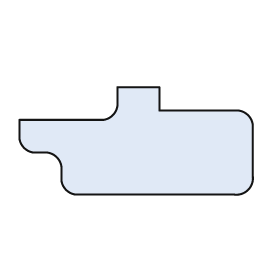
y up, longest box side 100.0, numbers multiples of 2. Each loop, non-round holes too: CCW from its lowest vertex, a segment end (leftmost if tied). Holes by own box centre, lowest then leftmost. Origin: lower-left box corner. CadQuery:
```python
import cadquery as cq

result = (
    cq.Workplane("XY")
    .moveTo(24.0, 0.0)
    .lineTo(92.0, 0.0)
    .threePointArc((98.0, 2.0), (100.0, 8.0))
    .lineTo(100.0, 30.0)
    .threePointArc((98.0, 34.0), (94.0, 36.0))
    .lineTo(60.0, 36.0)
    .lineTo(60.0, 46.0)
    .lineTo(42.0, 46.0)
    .lineTo(42.0, 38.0)
    .threePointArc((40.0, 34.0), (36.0, 32.0))
    .lineTo(0.0, 32.0)
    .lineTo(0.0, 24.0)
    .threePointArc((2.0, 20.0), (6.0, 18.0))
    .lineTo(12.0, 18.0)
    .threePointArc((16.0, 16.0), (18.0, 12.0))
    .lineTo(18.0, 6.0)
    .threePointArc((20.0, 2.0), (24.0, 0.0))
    .close()
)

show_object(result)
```